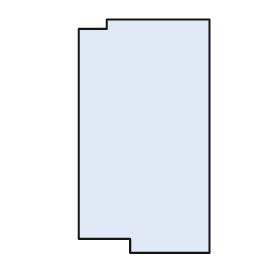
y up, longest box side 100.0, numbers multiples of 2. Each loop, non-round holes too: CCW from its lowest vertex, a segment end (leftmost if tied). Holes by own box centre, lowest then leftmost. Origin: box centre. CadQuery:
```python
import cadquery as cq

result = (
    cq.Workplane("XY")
    .moveTo(-6.0, -50.0)
    .lineTo(28.0, -50.0)
    .lineTo(28.0, 50.0)
    .lineTo(-16.0, 50.0)
    .lineTo(-16.0, 46.0)
    .lineTo(-28.0, 46.0)
    .lineTo(-28.0, -44.0)
    .lineTo(-6.0, -44.0)
    .close()
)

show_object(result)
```